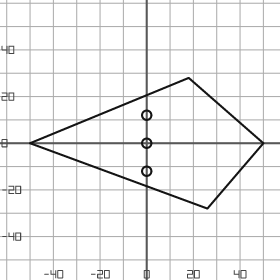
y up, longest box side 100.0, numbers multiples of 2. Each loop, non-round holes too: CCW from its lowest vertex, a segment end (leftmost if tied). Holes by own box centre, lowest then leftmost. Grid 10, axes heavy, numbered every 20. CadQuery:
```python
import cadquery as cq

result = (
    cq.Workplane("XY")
    .moveTo(26.0, -28.0)
    .lineTo(50.0, 0.0)
    .lineTo(18.0, 28.0)
    .lineTo(-50.0, 0.0)
    .close()
    .moveTo(0.0, -12.0)
    .circle(2.0)
    .moveTo(0.0, 0.0)
    .circle(2.0)
    .moveTo(0.0, 12.0)
    .circle(2.0)
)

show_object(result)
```